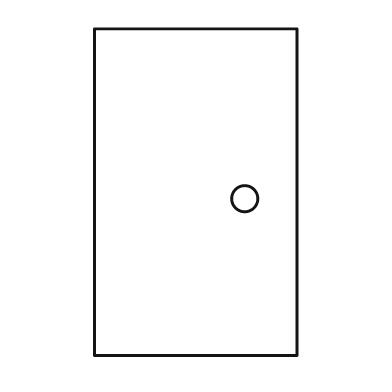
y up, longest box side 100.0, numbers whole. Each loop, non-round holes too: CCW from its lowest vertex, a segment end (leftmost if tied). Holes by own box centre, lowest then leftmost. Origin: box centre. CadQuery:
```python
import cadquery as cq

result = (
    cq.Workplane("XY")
    .moveTo(-31.0, -50.0)
    .lineTo(31.0, -50.0)
    .lineTo(31.0, 50.0)
    .lineTo(-31.0, 50.0)
    .close()
    .moveTo(15.0, -2.0)
    .circle(4.0)
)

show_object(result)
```